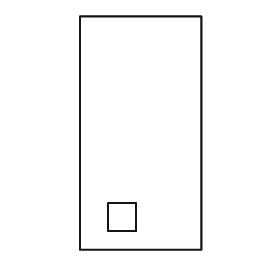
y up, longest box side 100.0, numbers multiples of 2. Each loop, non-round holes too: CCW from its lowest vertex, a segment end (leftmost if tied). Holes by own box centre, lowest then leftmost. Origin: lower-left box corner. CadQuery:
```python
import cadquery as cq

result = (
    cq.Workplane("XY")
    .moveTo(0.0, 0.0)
    .lineTo(52.0, 0.0)
    .lineTo(52.0, 100.0)
    .lineTo(0.0, 100.0)
    .close()
    .moveTo(12.0, 8.0)
    .lineTo(24.0, 8.0)
    .lineTo(24.0, 20.0)
    .lineTo(12.0, 20.0)
    .close()
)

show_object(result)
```